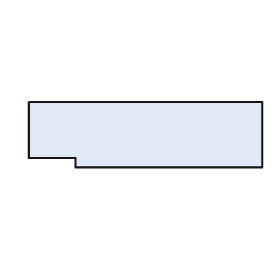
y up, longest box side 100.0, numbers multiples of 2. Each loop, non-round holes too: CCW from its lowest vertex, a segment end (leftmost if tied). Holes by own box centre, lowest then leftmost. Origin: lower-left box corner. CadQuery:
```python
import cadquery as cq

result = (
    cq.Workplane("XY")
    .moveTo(20.0, 0.0)
    .lineTo(100.0, 0.0)
    .lineTo(100.0, 28.0)
    .lineTo(0.0, 28.0)
    .lineTo(0.0, 4.0)
    .lineTo(20.0, 4.0)
    .close()
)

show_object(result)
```